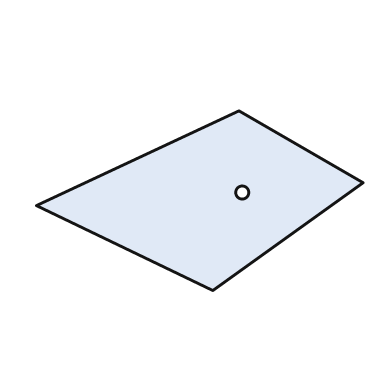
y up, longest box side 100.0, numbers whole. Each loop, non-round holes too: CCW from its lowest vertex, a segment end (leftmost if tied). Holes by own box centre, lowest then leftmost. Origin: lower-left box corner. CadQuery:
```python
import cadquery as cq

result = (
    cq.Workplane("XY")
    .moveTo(54.0, 0.0)
    .lineTo(100.0, 33.0)
    .lineTo(62.0, 55.0)
    .lineTo(0.0, 26.0)
    .close()
    .moveTo(63.0, 30.0)
    .circle(2.0)
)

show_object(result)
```